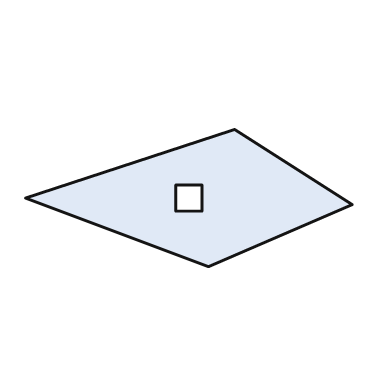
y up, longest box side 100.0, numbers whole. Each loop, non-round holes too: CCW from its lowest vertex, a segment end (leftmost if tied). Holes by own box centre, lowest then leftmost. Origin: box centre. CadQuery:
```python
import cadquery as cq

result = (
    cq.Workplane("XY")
    .moveTo(6.0, -21.0)
    .lineTo(50.0, -2.0)
    .lineTo(14.0, 21.0)
    .lineTo(-50.0, 0.0)
    .close()
    .moveTo(-4.0, -4.0)
    .lineTo(4.0, -4.0)
    .lineTo(4.0, 4.0)
    .lineTo(-4.0, 4.0)
    .close()
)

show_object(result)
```